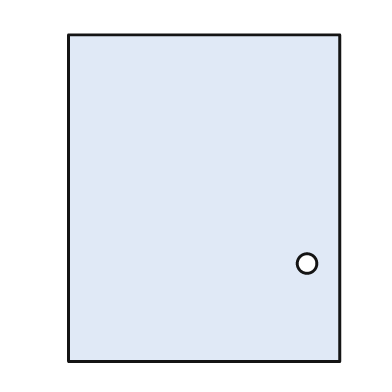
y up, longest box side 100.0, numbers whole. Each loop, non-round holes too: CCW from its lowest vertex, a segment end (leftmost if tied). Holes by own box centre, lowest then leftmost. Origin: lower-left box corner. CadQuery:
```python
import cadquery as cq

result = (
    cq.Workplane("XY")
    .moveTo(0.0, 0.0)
    .lineTo(83.0, 0.0)
    .lineTo(83.0, 100.0)
    .lineTo(0.0, 100.0)
    .close()
    .moveTo(73.0, 30.0)
    .circle(3.0)
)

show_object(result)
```